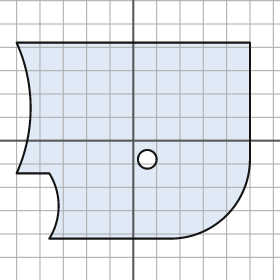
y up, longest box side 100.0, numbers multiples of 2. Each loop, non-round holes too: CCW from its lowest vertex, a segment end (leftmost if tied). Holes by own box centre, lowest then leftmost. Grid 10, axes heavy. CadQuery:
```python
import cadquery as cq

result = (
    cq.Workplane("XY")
    .moveTo(-36.0, -42.0)
    .lineTo(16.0, -42.0)
    .threePointArc((40.0, -32.0), (50.0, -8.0))
    .lineTo(50.0, 42.0)
    .lineTo(-50.0, 42.0)
    .threePointArc((-44.0, 14.0), (-50.0, -14.0))
    .lineTo(-36.0, -14.0)
    .threePointArc((-32.0, -28.0), (-36.0, -42.0))
    .close()
    .moveTo(6.0, -8.0)
    .circle(4.0)
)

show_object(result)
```